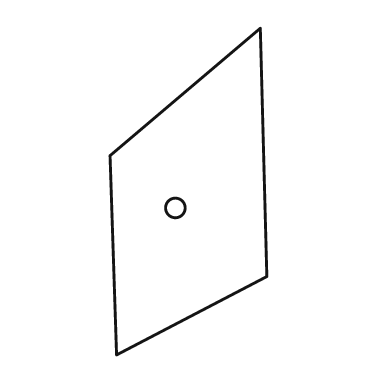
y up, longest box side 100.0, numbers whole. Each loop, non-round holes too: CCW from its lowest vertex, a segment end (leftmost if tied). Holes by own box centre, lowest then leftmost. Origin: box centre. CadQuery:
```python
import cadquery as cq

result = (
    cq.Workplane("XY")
    .moveTo(-22.0, -50.0)
    .lineTo(24.0, -26.0)
    .lineTo(22.0, 50.0)
    .lineTo(-24.0, 11.0)
    .close()
    .moveTo(-4.0, -5.0)
    .circle(3.0)
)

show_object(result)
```